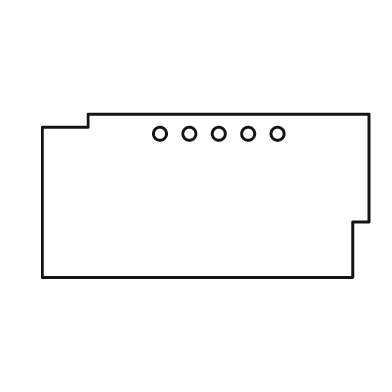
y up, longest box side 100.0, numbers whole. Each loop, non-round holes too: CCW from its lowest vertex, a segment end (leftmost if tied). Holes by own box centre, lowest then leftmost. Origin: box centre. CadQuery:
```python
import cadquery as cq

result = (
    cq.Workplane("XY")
    .moveTo(-50.0, -25.0)
    .lineTo(45.0, -25.0)
    .lineTo(45.0, -8.0)
    .lineTo(50.0, -8.0)
    .lineTo(50.0, 25.0)
    .lineTo(-36.0, 25.0)
    .lineTo(-36.0, 21.0)
    .lineTo(-50.0, 21.0)
    .close()
    .moveTo(-14.0, 19.0)
    .circle(2.0)
    .moveTo(-5.0, 19.0)
    .circle(2.0)
    .moveTo(4.0, 19.0)
    .circle(2.0)
    .moveTo(13.0, 19.0)
    .circle(2.0)
    .moveTo(22.0, 19.0)
    .circle(2.0)
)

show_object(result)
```